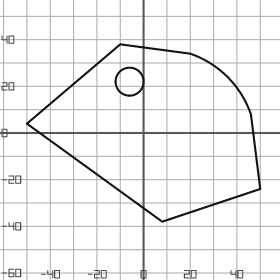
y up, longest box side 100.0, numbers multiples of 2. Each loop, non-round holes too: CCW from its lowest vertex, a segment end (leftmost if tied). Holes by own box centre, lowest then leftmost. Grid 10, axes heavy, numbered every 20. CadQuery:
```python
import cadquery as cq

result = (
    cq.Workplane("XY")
    .moveTo(8.0, -38.0)
    .lineTo(50.0, -24.0)
    .lineTo(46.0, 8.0)
    .threePointArc((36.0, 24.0), (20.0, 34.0))
    .lineTo(-10.0, 38.0)
    .lineTo(-50.0, 4.0)
    .close()
    .moveTo(-6.0, 22.0)
    .circle(6.0)
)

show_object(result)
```